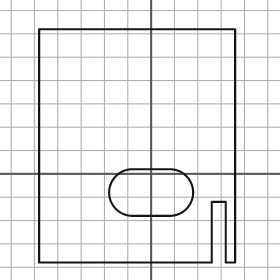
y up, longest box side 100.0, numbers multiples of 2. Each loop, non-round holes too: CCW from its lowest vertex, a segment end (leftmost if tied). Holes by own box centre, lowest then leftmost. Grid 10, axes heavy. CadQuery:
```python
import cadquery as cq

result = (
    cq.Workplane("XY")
    .moveTo(-48.0, -38.0)
    .lineTo(26.0, -38.0)
    .lineTo(26.0, -12.0)
    .lineTo(32.0, -12.0)
    .lineTo(32.0, -38.0)
    .lineTo(36.0, -38.0)
    .lineTo(36.0, 62.0)
    .lineTo(-48.0, 62.0)
    .close()
    .moveTo(-8.0, -18.0)
    .lineTo(8.0, -18.0)
    .threePointArc((18.0, -8.0), (8.0, 2.0))
    .lineTo(-8.0, 2.0)
    .threePointArc((-18.0, -8.0), (-8.0, -18.0))
    .close()
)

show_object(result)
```